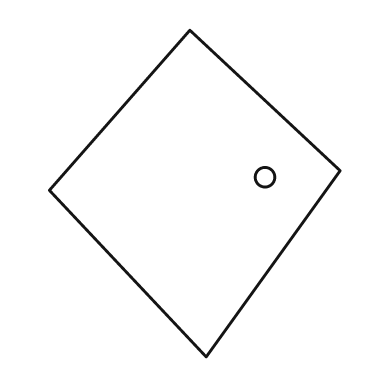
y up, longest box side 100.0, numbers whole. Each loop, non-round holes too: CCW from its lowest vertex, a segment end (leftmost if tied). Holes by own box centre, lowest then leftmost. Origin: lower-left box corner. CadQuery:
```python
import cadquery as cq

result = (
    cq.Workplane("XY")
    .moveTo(48.0, 0.0)
    .lineTo(89.0, 57.0)
    .lineTo(43.0, 100.0)
    .lineTo(0.0, 51.0)
    .close()
    .moveTo(66.0, 55.0)
    .circle(3.0)
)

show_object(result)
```